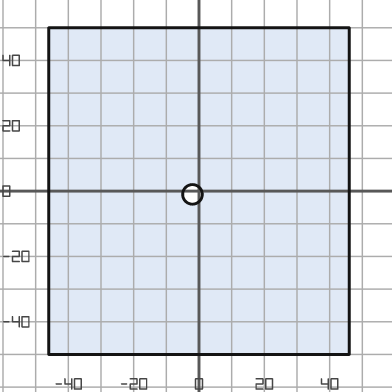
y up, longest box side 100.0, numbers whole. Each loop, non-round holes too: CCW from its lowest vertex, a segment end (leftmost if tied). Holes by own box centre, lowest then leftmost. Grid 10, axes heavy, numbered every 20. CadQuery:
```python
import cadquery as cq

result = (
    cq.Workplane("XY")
    .moveTo(-46.0, -50.0)
    .lineTo(46.0, -50.0)
    .lineTo(46.0, 50.0)
    .lineTo(-46.0, 50.0)
    .close()
    .moveTo(-2.0, -1.0)
    .circle(3.0)
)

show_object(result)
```